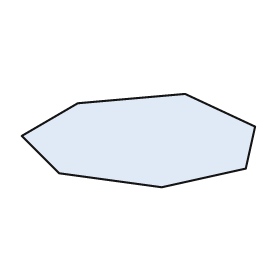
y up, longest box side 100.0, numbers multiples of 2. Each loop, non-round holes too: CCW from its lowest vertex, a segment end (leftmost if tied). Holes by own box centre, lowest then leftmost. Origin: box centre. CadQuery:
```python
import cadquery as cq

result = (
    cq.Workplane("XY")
    .moveTo(10.0, -20.0)
    .lineTo(46.0, -12.0)
    .lineTo(50.0, 6.0)
    .lineTo(20.0, 20.0)
    .lineTo(-26.0, 16.0)
    .lineTo(-50.0, 2.0)
    .lineTo(-34.0, -14.0)
    .close()
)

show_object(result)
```